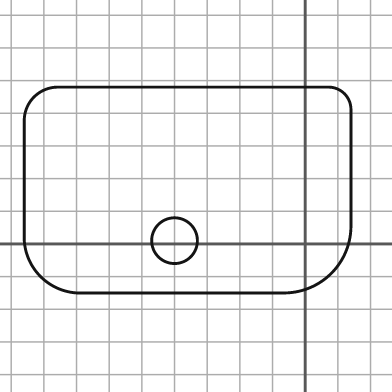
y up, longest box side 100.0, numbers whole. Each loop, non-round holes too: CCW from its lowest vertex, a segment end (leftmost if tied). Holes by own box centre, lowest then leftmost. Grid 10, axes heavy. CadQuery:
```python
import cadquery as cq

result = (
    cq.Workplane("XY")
    .moveTo(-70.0, -15.0)
    .lineTo(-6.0, -15.0)
    .threePointArc((8.0, -9.0), (14.0, 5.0))
    .lineTo(14.0, 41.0)
    .threePointArc((12.0, 46.0), (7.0, 48.0))
    .lineTo(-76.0, 48.0)
    .threePointArc((-83.0, 45.0), (-86.0, 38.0))
    .lineTo(-86.0, 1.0)
    .threePointArc((-81.0, -10.0), (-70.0, -15.0))
    .close()
    .moveTo(-40.0, 1.0)
    .circle(7.0)
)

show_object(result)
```